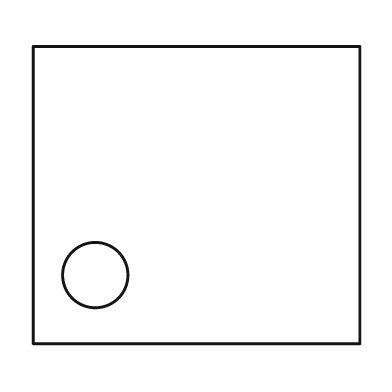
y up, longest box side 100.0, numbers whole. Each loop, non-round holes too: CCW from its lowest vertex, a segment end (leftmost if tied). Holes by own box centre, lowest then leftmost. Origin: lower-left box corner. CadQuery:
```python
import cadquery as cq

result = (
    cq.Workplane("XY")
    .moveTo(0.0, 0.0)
    .lineTo(100.0, 0.0)
    .lineTo(100.0, 91.0)
    .lineTo(0.0, 91.0)
    .close()
    .moveTo(19.0, 21.0)
    .circle(10.0)
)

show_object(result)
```